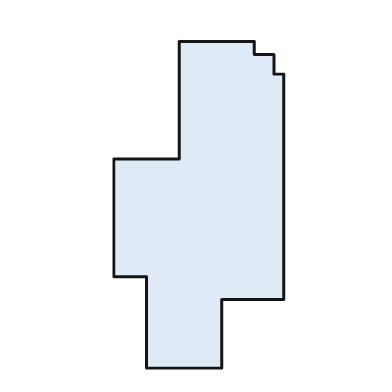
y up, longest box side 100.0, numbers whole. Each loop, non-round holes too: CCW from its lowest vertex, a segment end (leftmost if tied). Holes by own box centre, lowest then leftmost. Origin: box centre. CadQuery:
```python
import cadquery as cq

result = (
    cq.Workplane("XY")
    .moveTo(-16.0, -50.0)
    .lineTo(7.0, -50.0)
    .lineTo(7.0, -29.0)
    .lineTo(26.0, -29.0)
    .lineTo(26.0, 40.0)
    .lineTo(23.0, 40.0)
    .lineTo(23.0, 46.0)
    .lineTo(17.0, 46.0)
    .lineTo(17.0, 50.0)
    .lineTo(-6.0, 50.0)
    .lineTo(-6.0, 14.0)
    .lineTo(-26.0, 14.0)
    .lineTo(-26.0, -22.0)
    .lineTo(-16.0, -22.0)
    .close()
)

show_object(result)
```